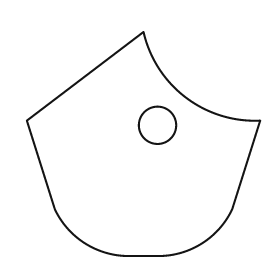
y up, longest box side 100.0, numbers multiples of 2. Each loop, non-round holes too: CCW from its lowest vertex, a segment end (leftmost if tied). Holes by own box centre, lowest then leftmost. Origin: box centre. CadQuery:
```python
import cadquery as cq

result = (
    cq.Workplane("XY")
    .moveTo(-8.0, -48.0)
    .lineTo(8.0, -48.0)
    .threePointArc((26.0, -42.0), (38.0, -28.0))
    .lineTo(50.0, 10.0)
    .threePointArc((18.0, 20.0), (0.0, 48.0))
    .lineTo(-50.0, 10.0)
    .lineTo(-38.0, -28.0)
    .threePointArc((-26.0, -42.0), (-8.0, -48.0))
    .close()
    .moveTo(6.0, 8.0)
    .circle(8.0)
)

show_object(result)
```